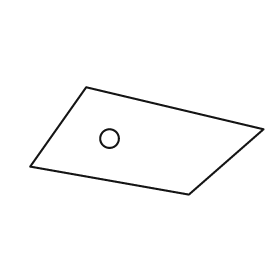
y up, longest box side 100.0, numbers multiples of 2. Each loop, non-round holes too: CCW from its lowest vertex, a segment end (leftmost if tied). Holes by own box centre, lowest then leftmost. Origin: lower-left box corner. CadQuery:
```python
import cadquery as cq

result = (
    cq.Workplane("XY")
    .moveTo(68.0, 0.0)
    .lineTo(100.0, 28.0)
    .lineTo(24.0, 46.0)
    .lineTo(0.0, 12.0)
    .close()
    .moveTo(34.0, 24.0)
    .circle(4.0)
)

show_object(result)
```